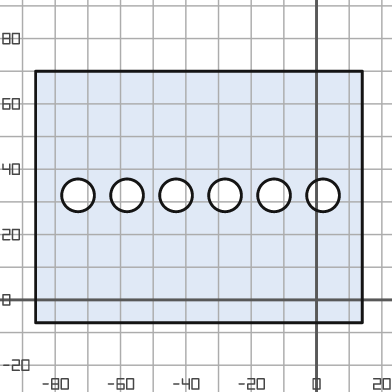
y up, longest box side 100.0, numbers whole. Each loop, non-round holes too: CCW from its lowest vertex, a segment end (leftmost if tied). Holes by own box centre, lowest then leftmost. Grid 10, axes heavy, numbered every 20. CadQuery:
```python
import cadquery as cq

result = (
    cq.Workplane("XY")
    .moveTo(-86.0, -7.0)
    .lineTo(14.0, -7.0)
    .lineTo(14.0, 70.0)
    .lineTo(-86.0, 70.0)
    .close()
    .moveTo(-73.0, 32.0)
    .circle(5.0)
    .moveTo(-58.0, 32.0)
    .circle(5.0)
    .moveTo(-43.0, 32.0)
    .circle(5.0)
    .moveTo(-28.0, 32.0)
    .circle(5.0)
    .moveTo(-13.0, 32.0)
    .circle(5.0)
    .moveTo(2.0, 32.0)
    .circle(5.0)
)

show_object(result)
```